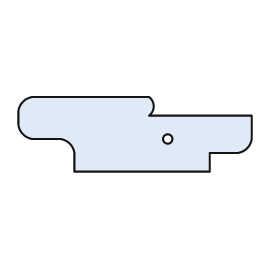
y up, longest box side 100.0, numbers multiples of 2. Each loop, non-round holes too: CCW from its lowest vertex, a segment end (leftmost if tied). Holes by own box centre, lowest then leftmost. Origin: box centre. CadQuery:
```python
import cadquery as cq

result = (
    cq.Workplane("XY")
    .moveTo(-26.0, -16.0)
    .lineTo(32.0, -16.0)
    .lineTo(32.0, -8.0)
    .lineTo(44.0, -8.0)
    .threePointArc((48.0, -6.0), (50.0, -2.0))
    .lineTo(50.0, 8.0)
    .lineTo(6.0, 8.0)
    .threePointArc((8.0, 12.0), (6.0, 16.0))
    .lineTo(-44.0, 16.0)
    .threePointArc((-48.0, 14.0), (-50.0, 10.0))
    .lineTo(-50.0, 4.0)
    .threePointArc((-48.0, 0.0), (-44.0, -2.0))
    .lineTo(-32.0, -2.0)
    .threePointArc((-28.0, -4.0), (-26.0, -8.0))
    .close()
    .moveTo(14.0, -2.0)
    .circle(2.0)
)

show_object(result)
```